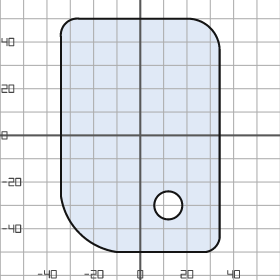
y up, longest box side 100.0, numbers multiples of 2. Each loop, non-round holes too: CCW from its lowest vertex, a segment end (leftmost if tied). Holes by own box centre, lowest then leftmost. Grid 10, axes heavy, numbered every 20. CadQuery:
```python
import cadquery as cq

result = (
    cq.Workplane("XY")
    .moveTo(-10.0, -50.0)
    .lineTo(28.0, -50.0)
    .threePointArc((32.0, -48.0), (34.0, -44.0))
    .lineTo(34.0, 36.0)
    .threePointArc((30.0, 46.0), (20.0, 50.0))
    .lineTo(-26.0, 50.0)
    .threePointArc((-32.0, 48.0), (-34.0, 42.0))
    .lineTo(-34.0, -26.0)
    .threePointArc((-26.0, -42.0), (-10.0, -50.0))
    .close()
    .moveTo(12.0, -30.0)
    .circle(6.0)
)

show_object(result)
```